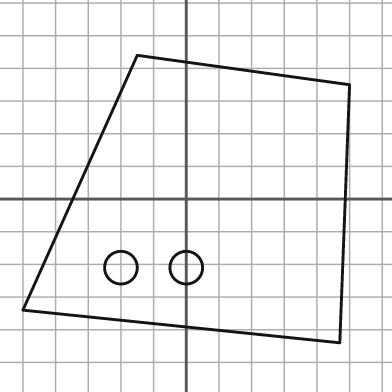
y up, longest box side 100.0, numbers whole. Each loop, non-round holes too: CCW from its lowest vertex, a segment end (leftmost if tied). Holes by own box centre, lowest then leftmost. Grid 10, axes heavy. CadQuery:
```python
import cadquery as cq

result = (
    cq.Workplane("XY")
    .moveTo(47.0, -44.0)
    .lineTo(50.0, 35.0)
    .lineTo(-15.0, 44.0)
    .lineTo(-50.0, -34.0)
    .close()
    .moveTo(-20.0, -21.0)
    .circle(5.0)
    .moveTo(0.0, -21.0)
    .circle(5.0)
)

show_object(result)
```